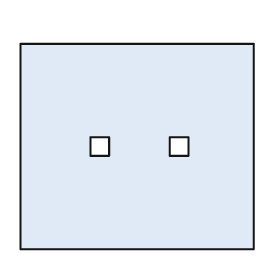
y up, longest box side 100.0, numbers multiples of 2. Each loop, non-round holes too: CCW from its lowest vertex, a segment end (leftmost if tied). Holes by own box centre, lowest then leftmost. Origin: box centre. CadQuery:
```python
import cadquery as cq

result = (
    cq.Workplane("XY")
    .moveTo(-50.0, -44.0)
    .lineTo(50.0, -44.0)
    .lineTo(50.0, 44.0)
    .lineTo(-50.0, 44.0)
    .close()
    .moveTo(-20.0, -4.0)
    .lineTo(-12.0, -4.0)
    .lineTo(-12.0, 4.0)
    .lineTo(-20.0, 4.0)
    .close()
    .moveTo(14.0, -4.0)
    .lineTo(22.0, -4.0)
    .lineTo(22.0, 4.0)
    .lineTo(14.0, 4.0)
    .close()
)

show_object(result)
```